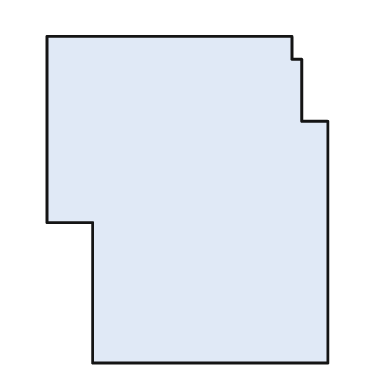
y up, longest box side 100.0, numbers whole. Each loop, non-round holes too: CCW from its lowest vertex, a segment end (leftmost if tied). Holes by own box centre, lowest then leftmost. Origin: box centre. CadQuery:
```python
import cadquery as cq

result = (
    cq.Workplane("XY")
    .moveTo(-29.0, -50.0)
    .lineTo(43.0, -50.0)
    .lineTo(43.0, 24.0)
    .lineTo(35.0, 24.0)
    .lineTo(35.0, 43.0)
    .lineTo(32.0, 43.0)
    .lineTo(32.0, 50.0)
    .lineTo(-43.0, 50.0)
    .lineTo(-43.0, -7.0)
    .lineTo(-29.0, -7.0)
    .close()
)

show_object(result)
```